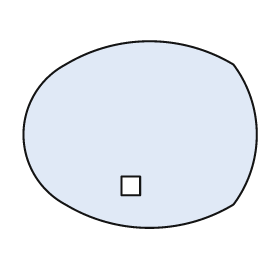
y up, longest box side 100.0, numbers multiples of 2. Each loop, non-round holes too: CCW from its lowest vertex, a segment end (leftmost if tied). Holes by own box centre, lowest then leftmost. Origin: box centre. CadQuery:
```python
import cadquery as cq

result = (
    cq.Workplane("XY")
    .moveTo(-32.0, -30.0)
    .threePointArc((4.0, -40.0), (40.0, -30.0))
    .threePointArc((50.0, 0.0), (40.0, 30.0))
    .threePointArc((4.0, 40.0), (-32.0, 30.0))
    .threePointArc((-50.0, 0.0), (-32.0, -30.0))
    .close()
    .moveTo(-8.0, -26.0)
    .lineTo(0.0, -26.0)
    .lineTo(0.0, -18.0)
    .lineTo(-8.0, -18.0)
    .close()
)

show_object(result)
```